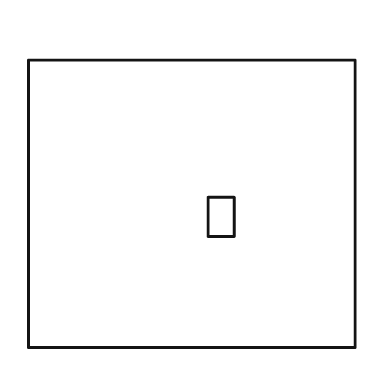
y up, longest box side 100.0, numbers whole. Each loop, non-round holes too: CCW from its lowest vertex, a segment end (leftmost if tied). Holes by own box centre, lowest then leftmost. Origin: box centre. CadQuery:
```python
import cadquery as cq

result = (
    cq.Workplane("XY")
    .moveTo(-50.0, -44.0)
    .lineTo(50.0, -44.0)
    .lineTo(50.0, 44.0)
    .lineTo(-50.0, 44.0)
    .close()
    .moveTo(5.0, -10.0)
    .lineTo(13.0, -10.0)
    .lineTo(13.0, 2.0)
    .lineTo(5.0, 2.0)
    .close()
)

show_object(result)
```